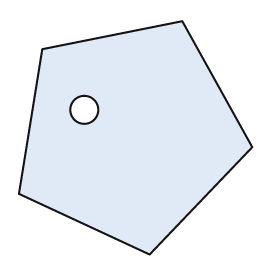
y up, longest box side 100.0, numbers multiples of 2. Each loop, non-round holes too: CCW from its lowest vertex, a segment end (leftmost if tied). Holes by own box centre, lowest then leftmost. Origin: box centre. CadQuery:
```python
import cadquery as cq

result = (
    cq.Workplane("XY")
    .moveTo(6.0, -50.0)
    .lineTo(50.0, -4.0)
    .lineTo(20.0, 50.0)
    .lineTo(-40.0, 38.0)
    .lineTo(-50.0, -24.0)
    .close()
    .moveTo(-22.0, 12.0)
    .circle(6.0)
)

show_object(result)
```